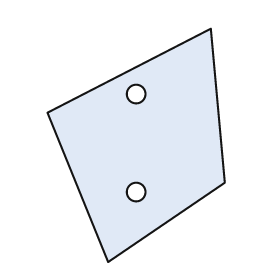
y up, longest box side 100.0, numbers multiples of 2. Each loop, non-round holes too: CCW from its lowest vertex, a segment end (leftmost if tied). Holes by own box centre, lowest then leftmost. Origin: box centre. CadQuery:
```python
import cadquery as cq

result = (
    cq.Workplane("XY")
    .moveTo(-12.0, -50.0)
    .lineTo(38.0, -16.0)
    .lineTo(32.0, 50.0)
    .lineTo(-38.0, 14.0)
    .close()
    .moveTo(0.0, -20.0)
    .circle(4.0)
    .moveTo(0.0, 22.0)
    .circle(4.0)
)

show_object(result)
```